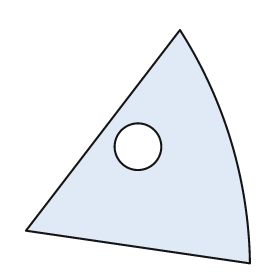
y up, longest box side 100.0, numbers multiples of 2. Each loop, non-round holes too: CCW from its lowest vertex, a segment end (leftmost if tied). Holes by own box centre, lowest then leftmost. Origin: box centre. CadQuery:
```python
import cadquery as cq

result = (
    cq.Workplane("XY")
    .moveTo(48.0, -50.0)
    .threePointArc((40.0, 2.0), (18.0, 50.0))
    .lineTo(-48.0, -36.0)
    .close()
    .moveTo(0.0, 0.0)
    .circle(10.0)
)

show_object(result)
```